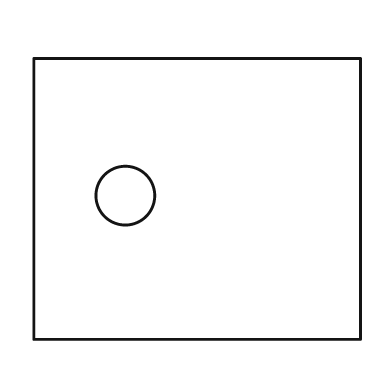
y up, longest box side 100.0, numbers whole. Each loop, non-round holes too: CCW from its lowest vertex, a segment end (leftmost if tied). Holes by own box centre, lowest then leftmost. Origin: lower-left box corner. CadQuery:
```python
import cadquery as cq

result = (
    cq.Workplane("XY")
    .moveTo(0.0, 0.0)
    .lineTo(100.0, 0.0)
    .lineTo(100.0, 86.0)
    .lineTo(0.0, 86.0)
    .close()
    .moveTo(28.0, 44.0)
    .circle(9.0)
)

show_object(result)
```